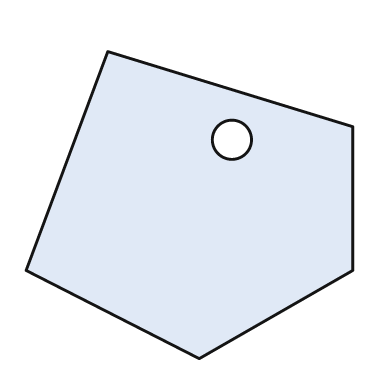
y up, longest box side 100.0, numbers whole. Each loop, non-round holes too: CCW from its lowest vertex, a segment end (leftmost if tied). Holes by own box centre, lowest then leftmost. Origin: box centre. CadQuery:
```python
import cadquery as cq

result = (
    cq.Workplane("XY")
    .moveTo(3.0, -47.0)
    .lineTo(50.0, -20.0)
    .lineTo(50.0, 24.0)
    .lineTo(-25.0, 47.0)
    .lineTo(-50.0, -20.0)
    .close()
    .moveTo(13.0, 20.0)
    .circle(6.0)
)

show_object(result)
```